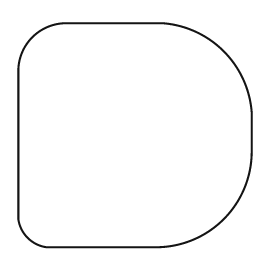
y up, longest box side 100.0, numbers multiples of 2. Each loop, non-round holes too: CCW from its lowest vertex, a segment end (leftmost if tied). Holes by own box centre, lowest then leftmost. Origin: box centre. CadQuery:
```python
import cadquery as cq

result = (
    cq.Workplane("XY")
    .moveTo(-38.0, -48.0)
    .lineTo(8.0, -48.0)
    .threePointArc((38.0, -36.0), (50.0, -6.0))
    .lineTo(50.0, 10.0)
    .threePointArc((38.0, 36.0), (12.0, 48.0))
    .lineTo(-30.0, 48.0)
    .threePointArc((-44.0, 42.0), (-50.0, 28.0))
    .lineTo(-50.0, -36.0)
    .threePointArc((-46.0, -44.0), (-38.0, -48.0))
    .close()
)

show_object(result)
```